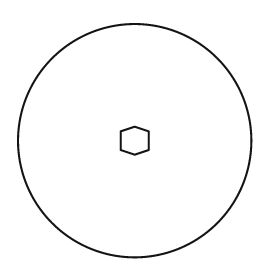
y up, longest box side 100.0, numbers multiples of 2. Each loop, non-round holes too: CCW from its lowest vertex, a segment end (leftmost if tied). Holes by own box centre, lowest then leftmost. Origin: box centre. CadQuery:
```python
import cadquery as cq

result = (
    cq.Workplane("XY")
    .moveTo(0.0, 0.0)
    .circle(50.0)
    .moveTo(0.0, -6.0)
    .lineTo(6.0, -4.0)
    .lineTo(6.0, 4.0)
    .lineTo(0.0, 6.0)
    .lineTo(-6.0, 4.0)
    .lineTo(-6.0, -4.0)
    .close()
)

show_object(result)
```